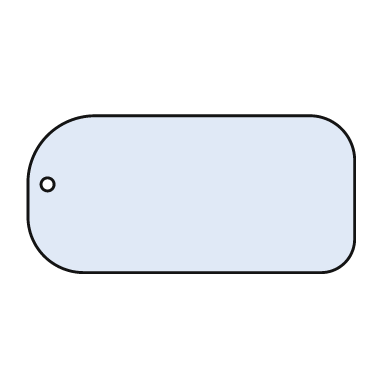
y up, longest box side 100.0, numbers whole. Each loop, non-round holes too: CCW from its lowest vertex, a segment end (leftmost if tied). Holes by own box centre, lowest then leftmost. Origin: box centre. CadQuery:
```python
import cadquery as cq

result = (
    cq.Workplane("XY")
    .moveTo(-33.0, -24.0)
    .lineTo(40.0, -24.0)
    .threePointArc((47.0, -21.0), (50.0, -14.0))
    .lineTo(50.0, 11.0)
    .threePointArc((46.0, 20.0), (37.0, 24.0))
    .lineTo(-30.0, 24.0)
    .threePointArc((-44.0, 18.0), (-50.0, 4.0))
    .lineTo(-50.0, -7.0)
    .threePointArc((-45.0, -19.0), (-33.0, -24.0))
    .close()
    .moveTo(-44.0, 3.0)
    .circle(2.0)
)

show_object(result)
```